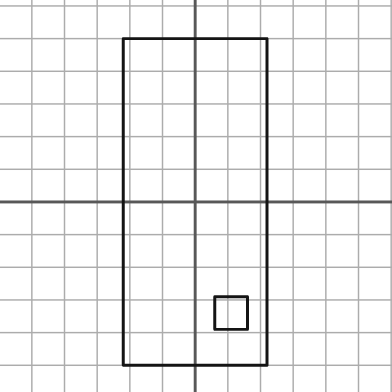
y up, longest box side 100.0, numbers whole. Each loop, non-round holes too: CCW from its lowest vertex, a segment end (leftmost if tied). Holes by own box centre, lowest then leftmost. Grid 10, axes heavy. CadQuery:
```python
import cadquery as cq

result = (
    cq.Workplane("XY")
    .moveTo(-22.0, -50.0)
    .lineTo(22.0, -50.0)
    .lineTo(22.0, 50.0)
    .lineTo(-22.0, 50.0)
    .close()
    .moveTo(6.0, -39.0)
    .lineTo(16.0, -39.0)
    .lineTo(16.0, -29.0)
    .lineTo(6.0, -29.0)
    .close()
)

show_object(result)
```